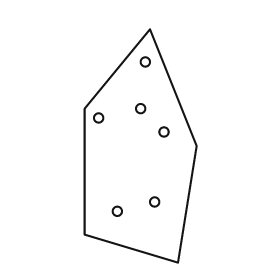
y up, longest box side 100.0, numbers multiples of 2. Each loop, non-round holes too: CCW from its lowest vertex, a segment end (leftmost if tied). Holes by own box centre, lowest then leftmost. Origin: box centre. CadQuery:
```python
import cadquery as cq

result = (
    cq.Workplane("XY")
    .moveTo(16.0, -50.0)
    .lineTo(24.0, 0.0)
    .lineTo(4.0, 50.0)
    .lineTo(-24.0, 16.0)
    .lineTo(-24.0, -38.0)
    .close()
    .moveTo(-10.0, -28.0)
    .circle(2.0)
    .moveTo(6.0, -24.0)
    .circle(2.0)
    .moveTo(10.0, 6.0)
    .circle(2.0)
    .moveTo(-18.0, 12.0)
    .circle(2.0)
    .moveTo(0.0, 16.0)
    .circle(2.0)
    .moveTo(2.0, 36.0)
    .circle(2.0)
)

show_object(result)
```